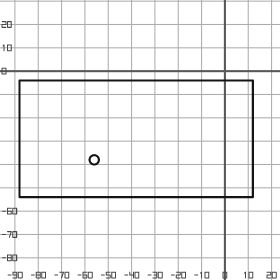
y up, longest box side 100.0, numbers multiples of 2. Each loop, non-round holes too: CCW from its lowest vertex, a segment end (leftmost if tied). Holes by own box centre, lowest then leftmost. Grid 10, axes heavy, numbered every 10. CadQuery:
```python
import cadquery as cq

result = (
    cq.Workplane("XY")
    .moveTo(-88.0, -54.0)
    .lineTo(12.0, -54.0)
    .lineTo(12.0, -4.0)
    .lineTo(-88.0, -4.0)
    .close()
    .moveTo(-56.0, -38.0)
    .circle(2.0)
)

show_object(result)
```